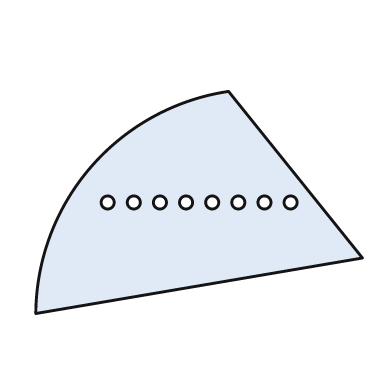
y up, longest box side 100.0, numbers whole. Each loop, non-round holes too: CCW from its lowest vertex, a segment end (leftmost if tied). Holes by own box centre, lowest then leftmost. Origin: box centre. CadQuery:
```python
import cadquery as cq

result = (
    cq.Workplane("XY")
    .moveTo(-50.0, -34.0)
    .lineTo(50.0, -17.0)
    .lineTo(9.0, 34.0)
    .threePointArc((-33.0, 11.0), (-50.0, -34.0))
    .close()
    .moveTo(-28.0, 0.0)
    .circle(2.0)
    .moveTo(-20.0, 0.0)
    .circle(2.0)
    .moveTo(-12.0, 0.0)
    .circle(2.0)
    .moveTo(-4.0, 0.0)
    .circle(2.0)
    .moveTo(4.0, 0.0)
    .circle(2.0)
    .moveTo(12.0, 0.0)
    .circle(2.0)
    .moveTo(20.0, 0.0)
    .circle(2.0)
    .moveTo(28.0, 0.0)
    .circle(2.0)
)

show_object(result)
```